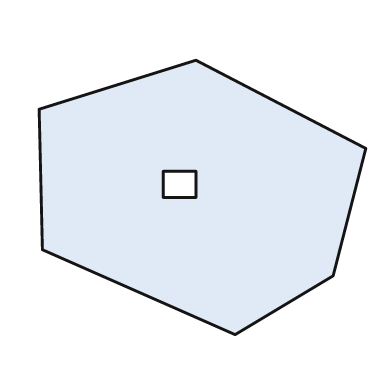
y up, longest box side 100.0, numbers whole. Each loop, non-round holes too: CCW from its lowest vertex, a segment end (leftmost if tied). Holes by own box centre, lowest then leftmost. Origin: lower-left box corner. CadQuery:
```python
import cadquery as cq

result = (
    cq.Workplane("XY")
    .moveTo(60.0, 0.0)
    .lineTo(90.0, 18.0)
    .lineTo(100.0, 57.0)
    .lineTo(48.0, 84.0)
    .lineTo(0.0, 69.0)
    .lineTo(1.0, 26.0)
    .close()
    .moveTo(38.0, 42.0)
    .lineTo(48.0, 42.0)
    .lineTo(48.0, 50.0)
    .lineTo(38.0, 50.0)
    .close()
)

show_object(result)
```